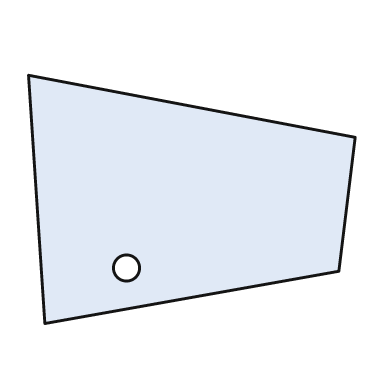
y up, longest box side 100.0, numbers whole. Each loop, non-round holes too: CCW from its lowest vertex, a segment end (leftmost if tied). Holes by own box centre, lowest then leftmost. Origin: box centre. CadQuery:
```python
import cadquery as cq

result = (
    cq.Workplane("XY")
    .moveTo(-45.0, -38.0)
    .lineTo(45.0, -22.0)
    .lineTo(50.0, 19.0)
    .lineTo(-50.0, 38.0)
    .close()
    .moveTo(-20.0, -21.0)
    .circle(4.0)
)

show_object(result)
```